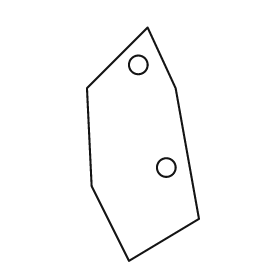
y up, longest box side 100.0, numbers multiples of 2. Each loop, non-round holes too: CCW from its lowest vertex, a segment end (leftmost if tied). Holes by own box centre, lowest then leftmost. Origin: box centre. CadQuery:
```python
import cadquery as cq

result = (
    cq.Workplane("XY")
    .moveTo(-6.0, -50.0)
    .lineTo(24.0, -32.0)
    .lineTo(14.0, 24.0)
    .lineTo(2.0, 50.0)
    .lineTo(-24.0, 24.0)
    .lineTo(-22.0, -18.0)
    .close()
    .moveTo(10.0, -10.0)
    .circle(4.0)
    .moveTo(-2.0, 34.0)
    .circle(4.0)
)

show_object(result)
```